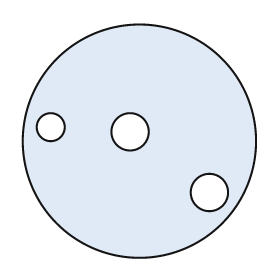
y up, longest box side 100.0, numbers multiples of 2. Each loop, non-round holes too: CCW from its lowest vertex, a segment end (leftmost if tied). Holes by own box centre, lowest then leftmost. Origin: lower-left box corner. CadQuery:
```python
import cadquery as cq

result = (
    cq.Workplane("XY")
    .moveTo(50.0, 50.0)
    .circle(50.0)
    .moveTo(80.0, 28.0)
    .circle(8.0)
    .moveTo(46.0, 54.0)
    .circle(8.0)
    .moveTo(12.0, 56.0)
    .circle(6.0)
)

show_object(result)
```